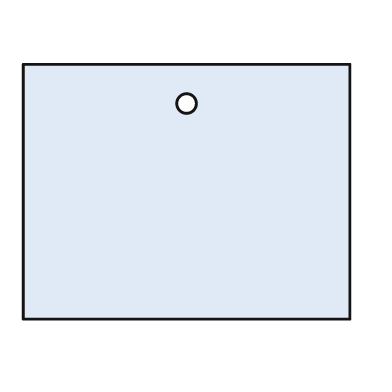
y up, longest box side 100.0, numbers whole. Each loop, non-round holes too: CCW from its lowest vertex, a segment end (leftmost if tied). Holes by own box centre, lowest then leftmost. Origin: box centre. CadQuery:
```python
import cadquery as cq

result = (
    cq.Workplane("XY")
    .moveTo(-50.0, -39.0)
    .lineTo(50.0, -39.0)
    .lineTo(50.0, 39.0)
    .lineTo(-50.0, 39.0)
    .close()
    .moveTo(0.0, 27.0)
    .circle(3.0)
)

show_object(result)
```